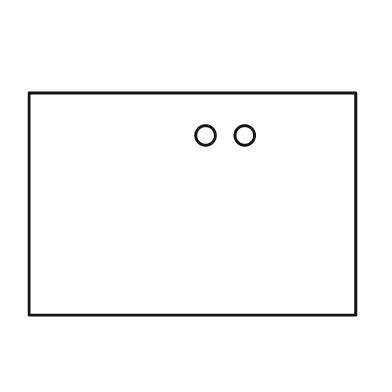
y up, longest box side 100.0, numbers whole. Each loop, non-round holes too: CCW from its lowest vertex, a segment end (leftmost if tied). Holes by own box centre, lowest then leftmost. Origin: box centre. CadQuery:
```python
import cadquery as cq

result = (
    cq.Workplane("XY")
    .moveTo(-50.0, -34.0)
    .lineTo(50.0, -34.0)
    .lineTo(50.0, 34.0)
    .lineTo(-50.0, 34.0)
    .close()
    .moveTo(4.0, 21.0)
    .circle(3.0)
    .moveTo(16.0, 21.0)
    .circle(3.0)
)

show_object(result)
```